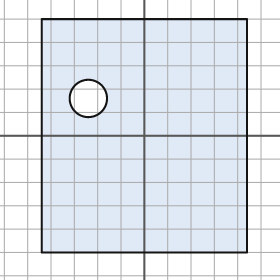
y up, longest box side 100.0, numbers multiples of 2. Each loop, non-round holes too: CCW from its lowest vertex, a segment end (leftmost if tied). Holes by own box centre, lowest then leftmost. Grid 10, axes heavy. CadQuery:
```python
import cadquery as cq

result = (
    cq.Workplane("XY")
    .moveTo(-44.0, -50.0)
    .lineTo(44.0, -50.0)
    .lineTo(44.0, 50.0)
    .lineTo(-44.0, 50.0)
    .close()
    .moveTo(-24.0, 16.0)
    .circle(8.0)
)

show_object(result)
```